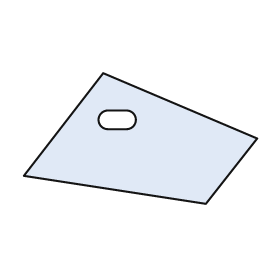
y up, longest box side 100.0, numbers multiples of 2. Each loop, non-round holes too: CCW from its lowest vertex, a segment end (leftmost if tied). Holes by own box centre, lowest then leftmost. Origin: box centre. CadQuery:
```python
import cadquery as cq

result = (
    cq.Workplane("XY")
    .moveTo(28.0, -28.0)
    .lineTo(50.0, 0.0)
    .lineTo(-16.0, 28.0)
    .lineTo(-50.0, -16.0)
    .close()
    .moveTo(-14.0, 4.0)
    .lineTo(-6.0, 4.0)
    .threePointArc((-2.0, 8.0), (-6.0, 12.0))
    .lineTo(-14.0, 12.0)
    .threePointArc((-18.0, 8.0), (-14.0, 4.0))
    .close()
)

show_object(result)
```